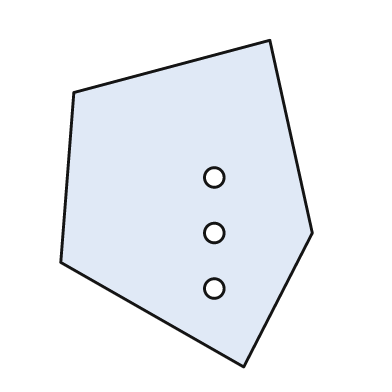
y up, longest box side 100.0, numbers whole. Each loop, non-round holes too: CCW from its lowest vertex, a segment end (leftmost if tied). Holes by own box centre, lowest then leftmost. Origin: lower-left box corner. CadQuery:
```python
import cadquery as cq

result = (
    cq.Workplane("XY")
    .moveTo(56.0, 0.0)
    .lineTo(77.0, 41.0)
    .lineTo(64.0, 100.0)
    .lineTo(4.0, 84.0)
    .lineTo(0.0, 32.0)
    .close()
    .moveTo(47.0, 24.0)
    .circle(3.0)
    .moveTo(47.0, 41.0)
    .circle(3.0)
    .moveTo(47.0, 58.0)
    .circle(3.0)
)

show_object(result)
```